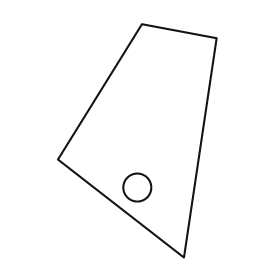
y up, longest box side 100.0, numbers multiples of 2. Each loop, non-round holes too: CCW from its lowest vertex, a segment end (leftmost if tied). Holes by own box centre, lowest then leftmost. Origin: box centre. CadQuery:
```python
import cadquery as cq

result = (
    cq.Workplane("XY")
    .moveTo(20.0, -50.0)
    .lineTo(34.0, 44.0)
    .lineTo(2.0, 50.0)
    .lineTo(-34.0, -8.0)
    .close()
    .moveTo(0.0, -20.0)
    .circle(6.0)
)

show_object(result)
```